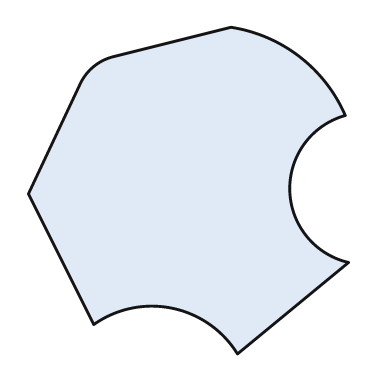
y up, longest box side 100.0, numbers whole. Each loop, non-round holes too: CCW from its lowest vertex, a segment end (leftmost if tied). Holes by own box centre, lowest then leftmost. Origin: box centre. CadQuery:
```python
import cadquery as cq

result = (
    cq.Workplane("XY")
    .moveTo(15.0, -50.0)
    .lineTo(49.0, -22.0)
    .threePointArc((31.0, 0.0), (48.0, 23.0))
    .threePointArc((34.0, 41.0), (13.0, 50.0))
    .lineTo(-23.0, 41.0)
    .threePointArc((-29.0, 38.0), (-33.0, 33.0))
    .lineTo(-49.0, -1.0)
    .lineTo(-29.0, -41.0)
    .threePointArc((-5.0, -36.0), (15.0, -50.0))
    .close()
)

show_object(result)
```